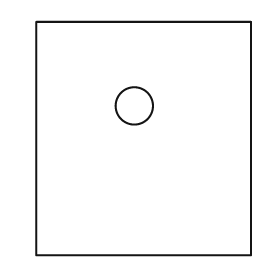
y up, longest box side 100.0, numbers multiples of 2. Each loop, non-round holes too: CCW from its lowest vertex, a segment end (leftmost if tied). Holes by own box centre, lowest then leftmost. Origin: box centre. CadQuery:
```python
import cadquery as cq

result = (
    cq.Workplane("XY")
    .moveTo(-46.0, -50.0)
    .lineTo(46.0, -50.0)
    .lineTo(46.0, 50.0)
    .lineTo(-46.0, 50.0)
    .close()
    .moveTo(-4.0, 14.0)
    .circle(8.0)
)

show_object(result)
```